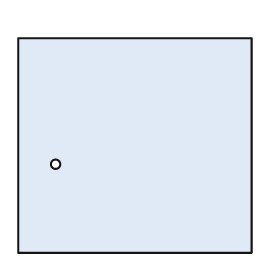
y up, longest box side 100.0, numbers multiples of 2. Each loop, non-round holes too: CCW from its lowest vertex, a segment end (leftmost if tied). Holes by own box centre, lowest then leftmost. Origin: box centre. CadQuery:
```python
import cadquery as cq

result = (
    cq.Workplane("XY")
    .moveTo(-50.0, -46.0)
    .lineTo(50.0, -46.0)
    .lineTo(50.0, 46.0)
    .lineTo(-50.0, 46.0)
    .close()
    .moveTo(-34.0, -8.0)
    .circle(2.0)
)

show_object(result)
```